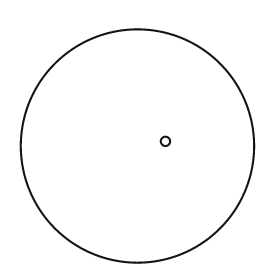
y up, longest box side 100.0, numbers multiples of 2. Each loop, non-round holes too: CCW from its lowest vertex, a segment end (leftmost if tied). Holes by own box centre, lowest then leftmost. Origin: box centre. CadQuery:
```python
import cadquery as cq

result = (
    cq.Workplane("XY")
    .moveTo(0.0, 0.0)
    .circle(50.0)
    .moveTo(12.0, 2.0)
    .circle(2.0)
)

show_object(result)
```